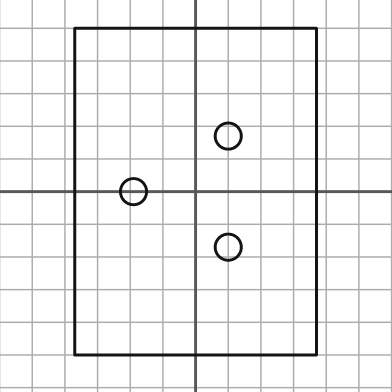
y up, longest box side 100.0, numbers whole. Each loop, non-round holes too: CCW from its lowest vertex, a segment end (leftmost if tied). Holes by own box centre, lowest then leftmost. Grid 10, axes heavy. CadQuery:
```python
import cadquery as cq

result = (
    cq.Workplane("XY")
    .moveTo(-37.0, -50.0)
    .lineTo(37.0, -50.0)
    .lineTo(37.0, 50.0)
    .lineTo(-37.0, 50.0)
    .close()
    .moveTo(10.0, -17.0)
    .circle(4.0)
    .moveTo(-19.0, 0.0)
    .circle(4.0)
    .moveTo(10.0, 17.0)
    .circle(4.0)
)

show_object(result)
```